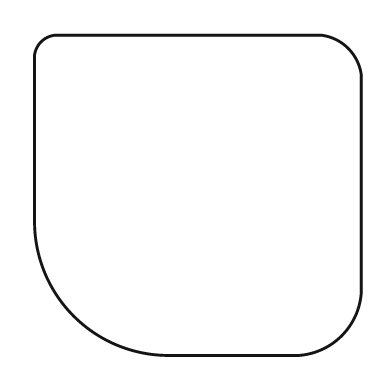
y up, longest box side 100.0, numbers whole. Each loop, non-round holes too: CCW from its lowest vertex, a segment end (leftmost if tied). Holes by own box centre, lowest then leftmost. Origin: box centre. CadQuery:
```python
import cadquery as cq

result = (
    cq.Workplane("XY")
    .moveTo(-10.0, -49.0)
    .lineTo(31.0, -49.0)
    .threePointArc((44.0, -43.0), (50.0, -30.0))
    .lineTo(50.0, 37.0)
    .threePointArc((46.0, 45.0), (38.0, 49.0))
    .lineTo(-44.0, 49.0)
    .threePointArc((-48.0, 47.0), (-50.0, 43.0))
    .lineTo(-50.0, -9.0)
    .threePointArc((-38.0, -37.0), (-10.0, -49.0))
    .close()
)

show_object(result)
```